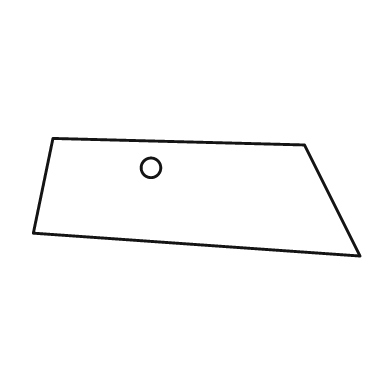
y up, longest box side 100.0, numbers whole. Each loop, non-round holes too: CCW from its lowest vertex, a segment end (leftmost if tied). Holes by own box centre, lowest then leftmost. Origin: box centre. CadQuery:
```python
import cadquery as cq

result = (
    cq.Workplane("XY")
    .moveTo(50.0, -18.0)
    .lineTo(33.0, 16.0)
    .lineTo(-44.0, 18.0)
    .lineTo(-50.0, -11.0)
    .close()
    .moveTo(-14.0, 9.0)
    .circle(3.0)
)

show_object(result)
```